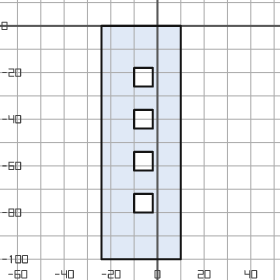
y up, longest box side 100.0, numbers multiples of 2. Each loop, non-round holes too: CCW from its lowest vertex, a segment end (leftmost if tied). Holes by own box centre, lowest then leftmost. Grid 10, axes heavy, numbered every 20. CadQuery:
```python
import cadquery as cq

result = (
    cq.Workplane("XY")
    .moveTo(-24.0, -100.0)
    .lineTo(10.0, -100.0)
    .lineTo(10.0, 0.0)
    .lineTo(-24.0, 0.0)
    .close()
    .moveTo(-10.0, -80.0)
    .lineTo(-2.0, -80.0)
    .lineTo(-2.0, -72.0)
    .lineTo(-10.0, -72.0)
    .close()
    .moveTo(-10.0, -62.0)
    .lineTo(-2.0, -62.0)
    .lineTo(-2.0, -54.0)
    .lineTo(-10.0, -54.0)
    .close()
    .moveTo(-10.0, -44.0)
    .lineTo(-2.0, -44.0)
    .lineTo(-2.0, -36.0)
    .lineTo(-10.0, -36.0)
    .close()
    .moveTo(-10.0, -26.0)
    .lineTo(-2.0, -26.0)
    .lineTo(-2.0, -18.0)
    .lineTo(-10.0, -18.0)
    .close()
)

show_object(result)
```